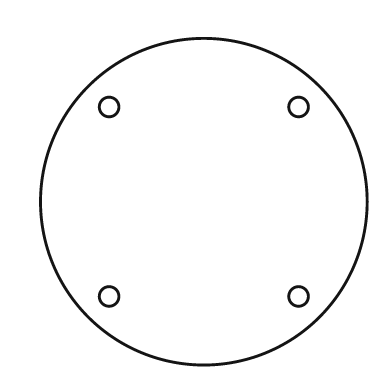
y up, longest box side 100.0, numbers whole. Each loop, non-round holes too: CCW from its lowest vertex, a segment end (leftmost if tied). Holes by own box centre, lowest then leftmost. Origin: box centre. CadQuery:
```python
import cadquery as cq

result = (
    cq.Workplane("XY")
    .moveTo(0.0, 0.0)
    .circle(50.0)
    .moveTo(-29.0, -29.0)
    .circle(3.0)
    .moveTo(29.0, -29.0)
    .circle(3.0)
    .moveTo(-29.0, 29.0)
    .circle(3.0)
    .moveTo(29.0, 29.0)
    .circle(3.0)
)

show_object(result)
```